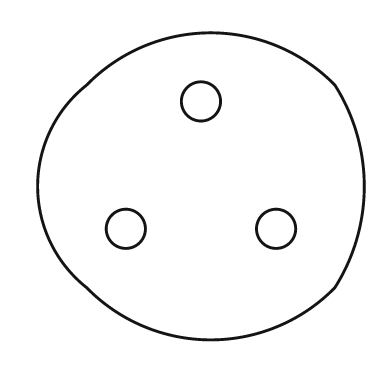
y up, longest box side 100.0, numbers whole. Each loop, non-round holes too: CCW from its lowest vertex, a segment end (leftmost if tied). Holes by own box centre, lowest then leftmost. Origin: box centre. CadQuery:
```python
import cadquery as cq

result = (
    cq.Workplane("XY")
    .moveTo(-35.0, -31.0)
    .threePointArc((3.0, -47.0), (41.0, -31.0))
    .threePointArc((50.0, 0.0), (41.0, 31.0))
    .threePointArc((3.0, 47.0), (-35.0, 31.0))
    .threePointArc((-50.0, 0.0), (-35.0, -31.0))
    .close()
    .moveTo(-23.0, -13.0)
    .circle(6.0)
    .moveTo(23.0, -13.0)
    .circle(6.0)
    .moveTo(0.0, 26.0)
    .circle(6.0)
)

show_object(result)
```